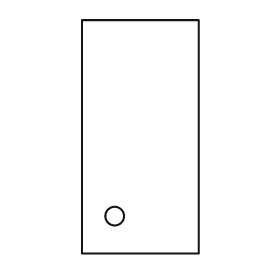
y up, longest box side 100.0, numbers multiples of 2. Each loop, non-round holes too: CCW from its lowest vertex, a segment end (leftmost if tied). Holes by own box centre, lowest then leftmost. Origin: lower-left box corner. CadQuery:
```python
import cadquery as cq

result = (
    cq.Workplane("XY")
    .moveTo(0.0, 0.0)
    .lineTo(50.0, 0.0)
    .lineTo(50.0, 100.0)
    .lineTo(0.0, 100.0)
    .close()
    .moveTo(14.0, 16.0)
    .circle(4.0)
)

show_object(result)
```